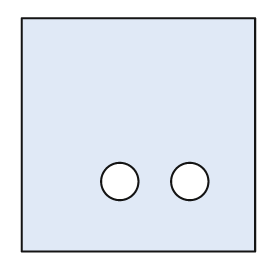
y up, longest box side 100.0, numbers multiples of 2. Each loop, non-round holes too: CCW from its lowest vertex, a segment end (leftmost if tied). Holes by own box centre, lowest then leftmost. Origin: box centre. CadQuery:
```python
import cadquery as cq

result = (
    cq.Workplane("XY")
    .moveTo(-50.0, -50.0)
    .lineTo(50.0, -50.0)
    .lineTo(50.0, 50.0)
    .lineTo(-50.0, 50.0)
    .close()
    .moveTo(-8.0, -20.0)
    .circle(8.0)
    .moveTo(22.0, -20.0)
    .circle(8.0)
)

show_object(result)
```